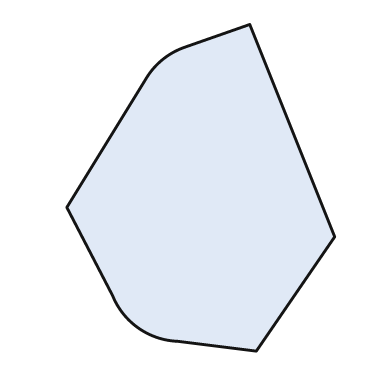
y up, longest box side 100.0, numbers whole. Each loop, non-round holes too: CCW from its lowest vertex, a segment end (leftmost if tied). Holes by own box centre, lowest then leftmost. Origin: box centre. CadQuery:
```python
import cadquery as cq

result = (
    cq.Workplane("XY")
    .moveTo(17.0, -50.0)
    .lineTo(41.0, -15.0)
    .lineTo(15.0, 50.0)
    .lineTo(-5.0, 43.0)
    .threePointArc((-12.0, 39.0), (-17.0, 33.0))
    .lineTo(-41.0, -6.0)
    .lineTo(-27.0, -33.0)
    .threePointArc((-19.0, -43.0), (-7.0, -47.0))
    .close()
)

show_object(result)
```